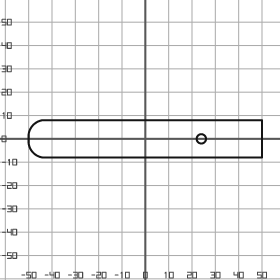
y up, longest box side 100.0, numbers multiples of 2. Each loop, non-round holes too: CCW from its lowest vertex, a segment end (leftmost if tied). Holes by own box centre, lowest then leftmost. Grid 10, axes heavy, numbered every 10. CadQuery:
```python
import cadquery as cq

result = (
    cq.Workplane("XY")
    .moveTo(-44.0, -8.0)
    .lineTo(50.0, -8.0)
    .lineTo(50.0, 8.0)
    .lineTo(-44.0, 8.0)
    .threePointArc((-48.0, 6.0), (-50.0, 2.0))
    .lineTo(-50.0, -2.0)
    .threePointArc((-48.0, -6.0), (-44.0, -8.0))
    .close()
    .moveTo(24.0, 0.0)
    .circle(2.0)
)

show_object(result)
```